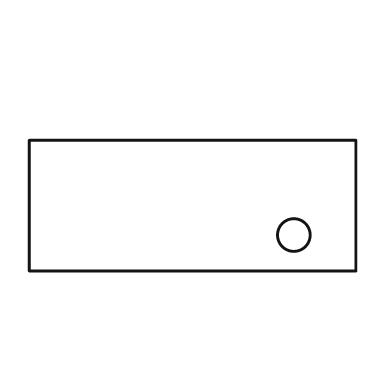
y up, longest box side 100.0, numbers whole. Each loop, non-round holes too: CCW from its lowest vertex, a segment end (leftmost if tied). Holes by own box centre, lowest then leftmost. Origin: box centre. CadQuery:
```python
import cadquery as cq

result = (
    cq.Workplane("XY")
    .moveTo(-50.0, -20.0)
    .lineTo(50.0, -20.0)
    .lineTo(50.0, 20.0)
    .lineTo(-50.0, 20.0)
    .close()
    .moveTo(31.0, -9.0)
    .circle(5.0)
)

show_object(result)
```